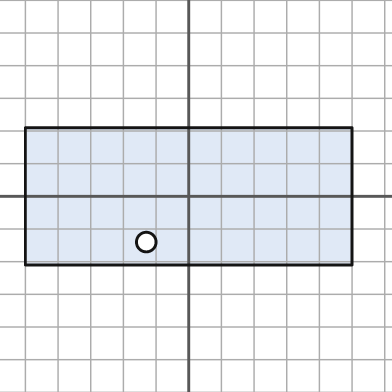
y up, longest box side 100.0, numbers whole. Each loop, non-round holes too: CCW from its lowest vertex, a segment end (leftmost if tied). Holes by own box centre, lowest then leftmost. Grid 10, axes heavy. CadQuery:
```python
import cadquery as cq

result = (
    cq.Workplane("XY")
    .moveTo(-50.0, -21.0)
    .lineTo(50.0, -21.0)
    .lineTo(50.0, 21.0)
    .lineTo(-50.0, 21.0)
    .close()
    .moveTo(-13.0, -14.0)
    .circle(3.0)
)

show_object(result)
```